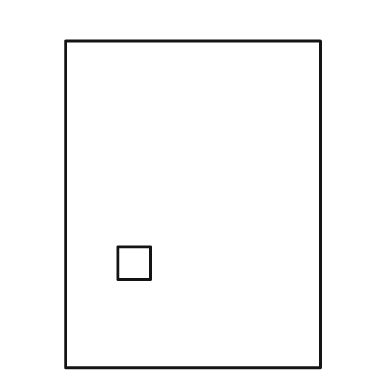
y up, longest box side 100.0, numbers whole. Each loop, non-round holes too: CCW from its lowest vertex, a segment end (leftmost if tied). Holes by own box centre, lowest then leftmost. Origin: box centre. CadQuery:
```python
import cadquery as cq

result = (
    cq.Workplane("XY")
    .moveTo(-39.0, -50.0)
    .lineTo(39.0, -50.0)
    .lineTo(39.0, 50.0)
    .lineTo(-39.0, 50.0)
    .close()
    .moveTo(-23.0, -23.0)
    .lineTo(-13.0, -23.0)
    .lineTo(-13.0, -13.0)
    .lineTo(-23.0, -13.0)
    .close()
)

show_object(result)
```